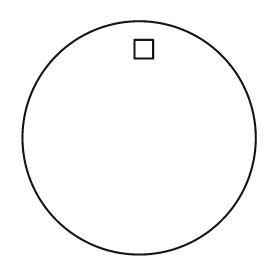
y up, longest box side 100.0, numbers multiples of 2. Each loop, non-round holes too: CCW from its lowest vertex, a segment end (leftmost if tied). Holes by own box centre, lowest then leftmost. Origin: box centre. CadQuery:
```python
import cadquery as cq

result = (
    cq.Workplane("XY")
    .moveTo(0.0, 0.0)
    .circle(50.0)
    .moveTo(-2.0, 34.0)
    .lineTo(6.0, 34.0)
    .lineTo(6.0, 42.0)
    .lineTo(-2.0, 42.0)
    .close()
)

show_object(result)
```